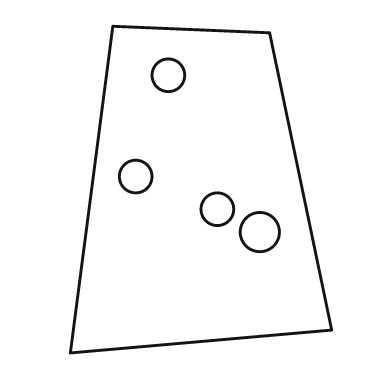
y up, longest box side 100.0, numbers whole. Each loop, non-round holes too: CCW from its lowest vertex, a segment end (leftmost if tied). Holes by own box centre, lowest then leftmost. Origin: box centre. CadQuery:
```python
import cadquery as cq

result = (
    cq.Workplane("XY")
    .moveTo(-40.0, -50.0)
    .lineTo(40.0, -43.0)
    .lineTo(21.0, 48.0)
    .lineTo(-27.0, 50.0)
    .close()
    .moveTo(18.0, -13.0)
    .circle(6.0)
    .moveTo(5.0, -6.0)
    .circle(5.0)
    .moveTo(-20.0, 4.0)
    .circle(5.0)
    .moveTo(-10.0, 35.0)
    .circle(5.0)
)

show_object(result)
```